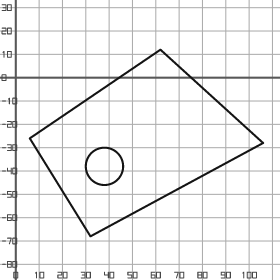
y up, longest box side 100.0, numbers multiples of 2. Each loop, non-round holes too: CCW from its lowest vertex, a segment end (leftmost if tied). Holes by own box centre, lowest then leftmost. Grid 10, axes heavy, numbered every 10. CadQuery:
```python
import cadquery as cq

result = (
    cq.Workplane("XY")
    .moveTo(32.0, -68.0)
    .lineTo(106.0, -28.0)
    .lineTo(62.0, 12.0)
    .lineTo(6.0, -26.0)
    .close()
    .moveTo(38.0, -38.0)
    .circle(8.0)
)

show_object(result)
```